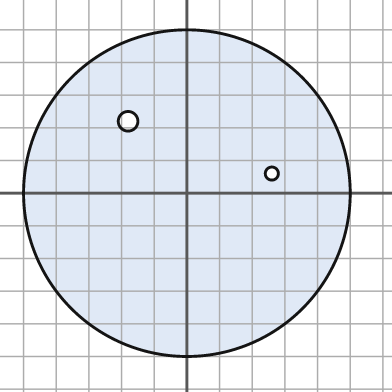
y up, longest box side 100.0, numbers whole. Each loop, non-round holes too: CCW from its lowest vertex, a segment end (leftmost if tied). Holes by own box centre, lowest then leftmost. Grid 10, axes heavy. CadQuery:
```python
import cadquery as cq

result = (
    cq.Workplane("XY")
    .moveTo(0.0, 0.0)
    .circle(50.0)
    .moveTo(26.0, 6.0)
    .circle(2.0)
    .moveTo(-18.0, 22.0)
    .circle(3.0)
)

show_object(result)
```